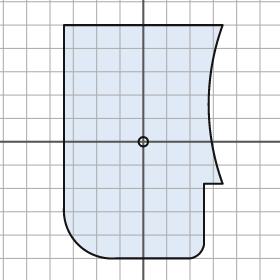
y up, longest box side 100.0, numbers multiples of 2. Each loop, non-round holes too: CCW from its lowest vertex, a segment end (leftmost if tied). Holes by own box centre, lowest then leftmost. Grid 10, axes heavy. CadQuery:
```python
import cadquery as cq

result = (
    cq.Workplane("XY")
    .moveTo(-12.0, -50.0)
    .lineTo(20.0, -50.0)
    .threePointArc((24.0, -48.0), (26.0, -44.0))
    .lineTo(26.0, -18.0)
    .lineTo(34.0, -18.0)
    .threePointArc((28.0, 16.0), (34.0, 50.0))
    .lineTo(-34.0, 50.0)
    .lineTo(-34.0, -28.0)
    .threePointArc((-28.0, -44.0), (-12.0, -50.0))
    .close()
    .moveTo(0.0, 0.0)
    .circle(2.0)
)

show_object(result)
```